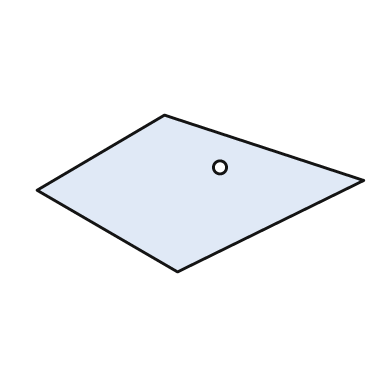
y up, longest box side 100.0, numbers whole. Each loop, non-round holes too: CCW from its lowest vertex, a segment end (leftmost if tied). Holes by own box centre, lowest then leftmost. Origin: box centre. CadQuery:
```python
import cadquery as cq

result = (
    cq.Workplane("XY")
    .moveTo(-7.0, -24.0)
    .lineTo(50.0, 4.0)
    .lineTo(-11.0, 24.0)
    .lineTo(-50.0, 1.0)
    .close()
    .moveTo(6.0, 8.0)
    .circle(2.0)
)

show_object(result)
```